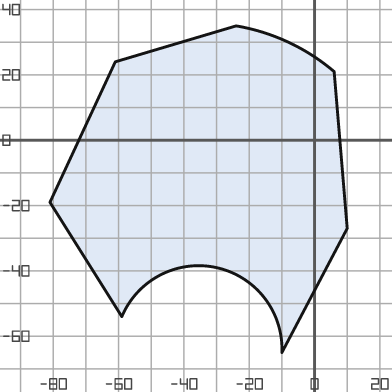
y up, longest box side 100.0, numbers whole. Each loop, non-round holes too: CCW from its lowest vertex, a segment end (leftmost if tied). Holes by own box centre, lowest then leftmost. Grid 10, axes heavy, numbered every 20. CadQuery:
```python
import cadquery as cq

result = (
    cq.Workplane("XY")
    .moveTo(-10.0, -65.0)
    .lineTo(10.0, -27.0)
    .lineTo(6.0, 21.0)
    .threePointArc((-8.0, 30.0), (-24.0, 35.0))
    .lineTo(-61.0, 24.0)
    .lineTo(-81.0, -19.0)
    .lineTo(-59.0, -54.0)
    .threePointArc((-30.0, -39.0), (-10.0, -65.0))
    .close()
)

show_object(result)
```